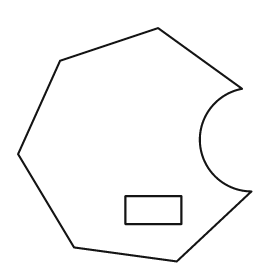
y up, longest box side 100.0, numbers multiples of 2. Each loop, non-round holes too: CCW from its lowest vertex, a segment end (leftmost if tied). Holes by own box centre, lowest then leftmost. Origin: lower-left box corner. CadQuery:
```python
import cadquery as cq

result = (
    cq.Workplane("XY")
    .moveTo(68.0, 0.0)
    .lineTo(100.0, 30.0)
    .threePointArc((78.0, 50.0), (96.0, 74.0))
    .lineTo(60.0, 100.0)
    .lineTo(18.0, 86.0)
    .lineTo(0.0, 46.0)
    .lineTo(24.0, 6.0)
    .close()
    .moveTo(46.0, 16.0)
    .lineTo(70.0, 16.0)
    .lineTo(70.0, 28.0)
    .lineTo(46.0, 28.0)
    .close()
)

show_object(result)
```